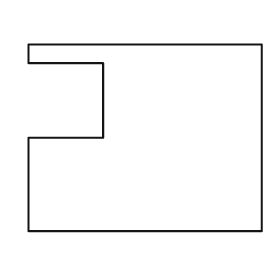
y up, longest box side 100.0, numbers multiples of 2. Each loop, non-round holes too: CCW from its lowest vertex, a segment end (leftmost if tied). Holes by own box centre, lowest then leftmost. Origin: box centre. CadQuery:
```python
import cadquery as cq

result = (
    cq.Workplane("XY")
    .moveTo(-50.0, -40.0)
    .lineTo(50.0, -40.0)
    .lineTo(50.0, 40.0)
    .lineTo(-50.0, 40.0)
    .lineTo(-50.0, 32.0)
    .lineTo(-18.0, 32.0)
    .lineTo(-18.0, 0.0)
    .lineTo(-50.0, 0.0)
    .close()
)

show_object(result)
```